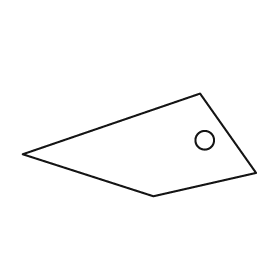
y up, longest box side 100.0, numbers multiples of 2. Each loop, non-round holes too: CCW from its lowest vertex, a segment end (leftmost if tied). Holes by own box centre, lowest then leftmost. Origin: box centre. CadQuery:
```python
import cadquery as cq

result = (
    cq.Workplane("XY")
    .moveTo(6.0, -22.0)
    .lineTo(50.0, -12.0)
    .lineTo(26.0, 22.0)
    .lineTo(-50.0, -4.0)
    .close()
    .moveTo(28.0, 2.0)
    .circle(4.0)
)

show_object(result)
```